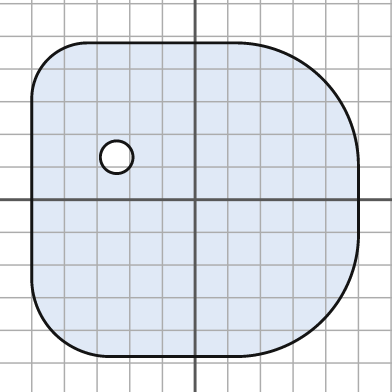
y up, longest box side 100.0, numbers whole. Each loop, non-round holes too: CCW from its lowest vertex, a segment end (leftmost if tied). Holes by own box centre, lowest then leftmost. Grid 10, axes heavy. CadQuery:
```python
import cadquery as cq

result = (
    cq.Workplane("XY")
    .moveTo(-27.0, -48.0)
    .lineTo(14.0, -48.0)
    .threePointArc((39.0, -37.0), (50.0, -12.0))
    .lineTo(50.0, 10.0)
    .threePointArc((39.0, 37.0), (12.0, 48.0))
    .lineTo(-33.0, 48.0)
    .threePointArc((-45.0, 43.0), (-50.0, 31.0))
    .lineTo(-50.0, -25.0)
    .threePointArc((-43.0, -41.0), (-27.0, -48.0))
    .close()
    .moveTo(-24.0, 13.0)
    .circle(5.0)
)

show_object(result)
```